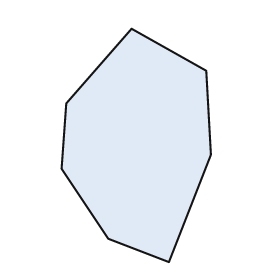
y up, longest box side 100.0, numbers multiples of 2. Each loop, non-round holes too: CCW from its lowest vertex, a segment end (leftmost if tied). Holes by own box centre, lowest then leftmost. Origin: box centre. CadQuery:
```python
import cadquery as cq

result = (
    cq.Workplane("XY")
    .moveTo(14.0, -50.0)
    .lineTo(32.0, -4.0)
    .lineTo(30.0, 32.0)
    .lineTo(-2.0, 50.0)
    .lineTo(-30.0, 18.0)
    .lineTo(-32.0, -10.0)
    .lineTo(-12.0, -40.0)
    .close()
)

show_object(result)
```